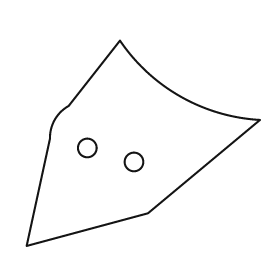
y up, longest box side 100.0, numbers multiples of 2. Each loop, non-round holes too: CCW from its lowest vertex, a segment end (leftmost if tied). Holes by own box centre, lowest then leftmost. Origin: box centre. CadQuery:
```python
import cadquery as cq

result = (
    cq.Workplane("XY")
    .moveTo(-50.0, -44.0)
    .lineTo(2.0, -30.0)
    .lineTo(50.0, 10.0)
    .threePointArc((16.0, 20.0), (-10.0, 44.0))
    .lineTo(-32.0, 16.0)
    .threePointArc((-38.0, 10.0), (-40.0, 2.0))
    .close()
    .moveTo(-4.0, -8.0)
    .circle(4.0)
    .moveTo(-24.0, -2.0)
    .circle(4.0)
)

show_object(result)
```